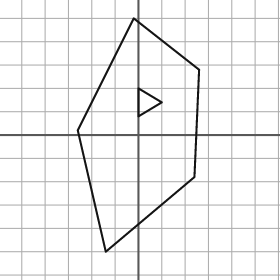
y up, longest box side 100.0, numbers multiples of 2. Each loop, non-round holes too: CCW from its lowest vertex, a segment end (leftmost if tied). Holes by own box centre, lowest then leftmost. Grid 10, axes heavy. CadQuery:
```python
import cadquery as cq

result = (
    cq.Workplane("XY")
    .moveTo(-14.0, -50.0)
    .lineTo(24.0, -18.0)
    .lineTo(26.0, 28.0)
    .lineTo(-2.0, 50.0)
    .lineTo(-26.0, 2.0)
    .close()
    .moveTo(0.0, 8.0)
    .lineTo(10.0, 14.0)
    .lineTo(0.0, 20.0)
    .close()
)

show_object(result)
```